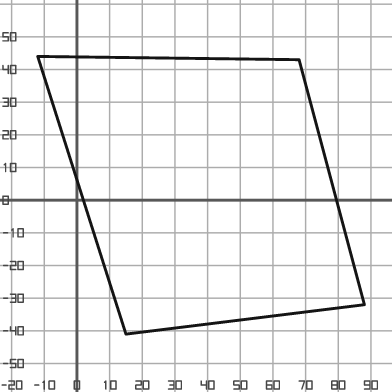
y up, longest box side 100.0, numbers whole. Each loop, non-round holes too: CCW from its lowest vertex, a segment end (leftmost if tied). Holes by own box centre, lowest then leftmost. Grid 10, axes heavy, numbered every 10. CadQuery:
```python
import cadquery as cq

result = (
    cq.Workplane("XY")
    .moveTo(15.0, -41.0)
    .lineTo(88.0, -32.0)
    .lineTo(68.0, 43.0)
    .lineTo(-12.0, 44.0)
    .close()
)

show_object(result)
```